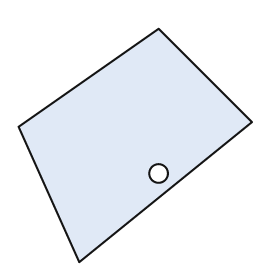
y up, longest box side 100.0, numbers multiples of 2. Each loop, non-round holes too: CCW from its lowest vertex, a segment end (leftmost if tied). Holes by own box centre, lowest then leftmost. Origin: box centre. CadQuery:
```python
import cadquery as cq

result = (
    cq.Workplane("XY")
    .moveTo(-24.0, -50.0)
    .lineTo(50.0, 10.0)
    .lineTo(10.0, 50.0)
    .lineTo(-50.0, 8.0)
    .close()
    .moveTo(10.0, -12.0)
    .circle(4.0)
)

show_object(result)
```